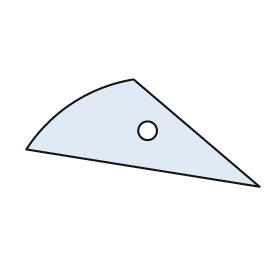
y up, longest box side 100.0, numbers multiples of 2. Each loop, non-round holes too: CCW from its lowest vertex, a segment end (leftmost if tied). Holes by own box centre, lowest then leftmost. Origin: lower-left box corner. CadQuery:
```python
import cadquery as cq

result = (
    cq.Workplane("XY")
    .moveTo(100.0, 0.0)
    .lineTo(46.0, 46.0)
    .threePointArc((20.0, 36.0), (0.0, 16.0))
    .close()
    .moveTo(52.0, 24.0)
    .circle(4.0)
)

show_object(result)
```